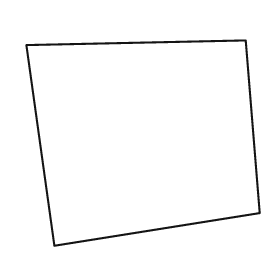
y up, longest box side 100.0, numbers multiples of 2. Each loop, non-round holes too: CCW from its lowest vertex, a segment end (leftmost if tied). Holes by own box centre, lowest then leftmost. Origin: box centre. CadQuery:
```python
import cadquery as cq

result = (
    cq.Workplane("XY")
    .moveTo(-38.0, -44.0)
    .lineTo(50.0, -30.0)
    .lineTo(44.0, 44.0)
    .lineTo(-50.0, 42.0)
    .close()
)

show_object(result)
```